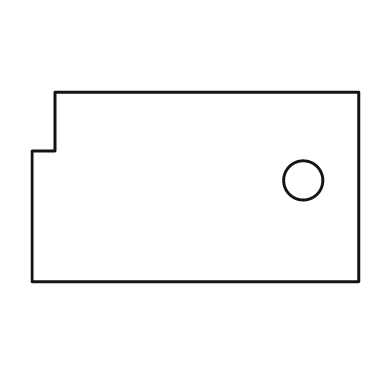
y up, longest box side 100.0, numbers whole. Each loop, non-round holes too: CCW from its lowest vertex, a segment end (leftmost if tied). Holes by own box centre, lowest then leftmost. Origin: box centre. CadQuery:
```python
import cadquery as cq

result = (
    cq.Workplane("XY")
    .moveTo(-50.0, -29.0)
    .lineTo(50.0, -29.0)
    .lineTo(50.0, 29.0)
    .lineTo(-43.0, 29.0)
    .lineTo(-43.0, 11.0)
    .lineTo(-50.0, 11.0)
    .close()
    .moveTo(33.0, 2.0)
    .circle(6.0)
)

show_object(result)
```